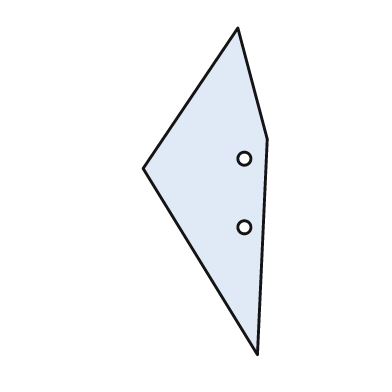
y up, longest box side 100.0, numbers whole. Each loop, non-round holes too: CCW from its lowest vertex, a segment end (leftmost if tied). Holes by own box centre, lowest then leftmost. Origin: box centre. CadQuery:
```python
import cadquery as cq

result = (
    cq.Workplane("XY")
    .moveTo(16.0, -50.0)
    .lineTo(19.0, 16.0)
    .lineTo(10.0, 50.0)
    .lineTo(-19.0, 7.0)
    .close()
    .moveTo(12.0, -11.0)
    .circle(2.0)
    .moveTo(12.0, 10.0)
    .circle(2.0)
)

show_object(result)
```